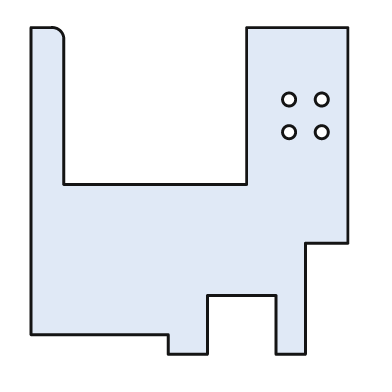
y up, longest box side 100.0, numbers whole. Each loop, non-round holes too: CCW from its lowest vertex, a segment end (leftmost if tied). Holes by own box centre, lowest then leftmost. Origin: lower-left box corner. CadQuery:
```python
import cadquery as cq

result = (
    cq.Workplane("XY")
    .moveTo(42.0, 0.0)
    .lineTo(54.0, 0.0)
    .lineTo(54.0, 18.0)
    .lineTo(75.0, 18.0)
    .lineTo(75.0, 0.0)
    .lineTo(84.0, 0.0)
    .lineTo(84.0, 34.0)
    .lineTo(97.0, 34.0)
    .lineTo(97.0, 100.0)
    .lineTo(66.0, 100.0)
    .lineTo(66.0, 52.0)
    .lineTo(10.0, 52.0)
    .lineTo(10.0, 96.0)
    .threePointArc((9.0, 99.0), (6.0, 100.0))
    .lineTo(0.0, 100.0)
    .lineTo(0.0, 6.0)
    .lineTo(42.0, 6.0)
    .close()
    .moveTo(79.0, 68.0)
    .circle(2.0)
    .moveTo(89.0, 68.0)
    .circle(2.0)
    .moveTo(79.0, 78.0)
    .circle(2.0)
    .moveTo(89.0, 78.0)
    .circle(2.0)
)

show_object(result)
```